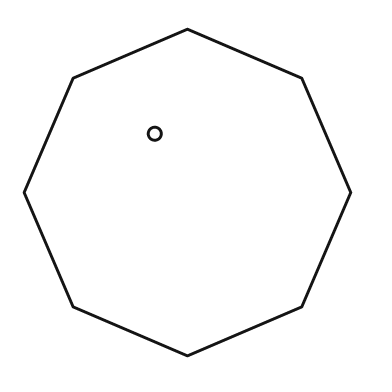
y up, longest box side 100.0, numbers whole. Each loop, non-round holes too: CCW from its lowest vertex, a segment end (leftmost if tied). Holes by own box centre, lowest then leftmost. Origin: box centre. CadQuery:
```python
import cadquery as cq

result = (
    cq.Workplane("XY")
    .moveTo(0.0, -50.0)
    .lineTo(35.0, -35.0)
    .lineTo(50.0, 0.0)
    .lineTo(35.0, 35.0)
    .lineTo(0.0, 50.0)
    .lineTo(-35.0, 35.0)
    .lineTo(-50.0, 0.0)
    .lineTo(-35.0, -35.0)
    .close()
    .moveTo(-10.0, 18.0)
    .circle(2.0)
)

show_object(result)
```